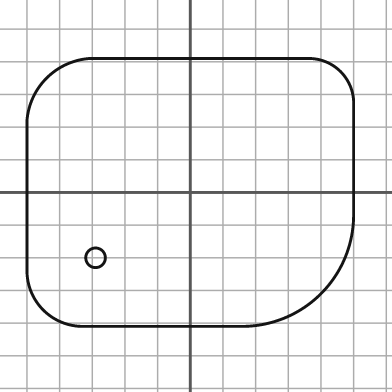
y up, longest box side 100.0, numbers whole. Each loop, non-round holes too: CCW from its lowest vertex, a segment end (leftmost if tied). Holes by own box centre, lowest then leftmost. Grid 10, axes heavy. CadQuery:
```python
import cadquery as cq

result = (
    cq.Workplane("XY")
    .moveTo(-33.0, -41.0)
    .lineTo(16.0, -41.0)
    .threePointArc((40.0, -31.0), (50.0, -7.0))
    .lineTo(50.0, 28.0)
    .threePointArc((46.0, 37.0), (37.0, 41.0))
    .lineTo(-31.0, 41.0)
    .threePointArc((-44.0, 35.0), (-50.0, 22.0))
    .lineTo(-50.0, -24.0)
    .threePointArc((-45.0, -36.0), (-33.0, -41.0))
    .close()
    .moveTo(-29.0, -20.0)
    .circle(3.0)
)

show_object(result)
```